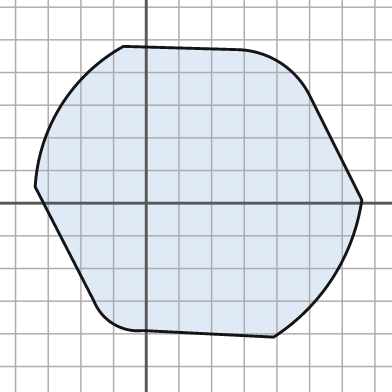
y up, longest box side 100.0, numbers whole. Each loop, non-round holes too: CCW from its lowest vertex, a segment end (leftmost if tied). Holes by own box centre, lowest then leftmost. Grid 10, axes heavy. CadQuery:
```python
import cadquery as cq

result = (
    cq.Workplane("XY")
    .moveTo(39.0, -41.0)
    .threePointArc((57.0, -23.0), (66.0, 1.0))
    .lineTo(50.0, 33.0)
    .threePointArc((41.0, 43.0), (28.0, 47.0))
    .lineTo(-7.0, 48.0)
    .threePointArc((-26.0, 30.0), (-34.0, 5.0))
    .lineTo(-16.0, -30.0)
    .threePointArc((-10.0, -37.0), (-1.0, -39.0))
    .close()
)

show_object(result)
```